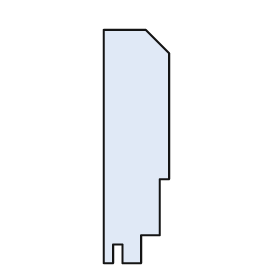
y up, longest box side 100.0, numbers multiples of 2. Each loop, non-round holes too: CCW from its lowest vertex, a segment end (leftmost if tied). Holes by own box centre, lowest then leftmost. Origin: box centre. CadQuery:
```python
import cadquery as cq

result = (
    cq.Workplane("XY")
    .moveTo(-14.0, -50.0)
    .lineTo(-10.0, -50.0)
    .lineTo(-10.0, -42.0)
    .lineTo(-6.0, -42.0)
    .lineTo(-6.0, -50.0)
    .lineTo(2.0, -50.0)
    .lineTo(2.0, -38.0)
    .lineTo(10.0, -38.0)
    .lineTo(10.0, -14.0)
    .lineTo(14.0, -14.0)
    .lineTo(14.0, 40.0)
    .lineTo(4.0, 50.0)
    .lineTo(-14.0, 50.0)
    .close()
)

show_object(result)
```